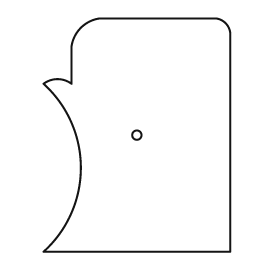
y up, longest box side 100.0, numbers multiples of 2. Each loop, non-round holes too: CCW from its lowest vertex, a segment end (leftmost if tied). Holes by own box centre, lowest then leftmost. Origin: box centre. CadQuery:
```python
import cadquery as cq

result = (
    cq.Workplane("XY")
    .moveTo(-40.0, -50.0)
    .lineTo(40.0, -50.0)
    .lineTo(40.0, 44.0)
    .threePointArc((38.0, 48.0), (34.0, 50.0))
    .lineTo(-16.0, 50.0)
    .threePointArc((-24.0, 46.0), (-28.0, 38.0))
    .lineTo(-28.0, 22.0)
    .threePointArc((-34.0, 24.0), (-40.0, 22.0))
    .threePointArc((-24.0, -14.0), (-40.0, -50.0))
    .close()
    .moveTo(0.0, 0.0)
    .circle(2.0)
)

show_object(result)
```